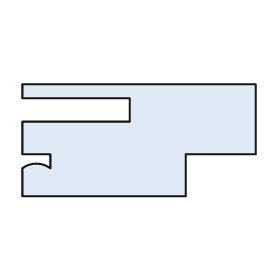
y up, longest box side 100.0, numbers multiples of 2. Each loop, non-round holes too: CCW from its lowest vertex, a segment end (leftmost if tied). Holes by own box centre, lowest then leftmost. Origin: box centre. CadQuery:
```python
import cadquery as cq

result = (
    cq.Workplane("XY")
    .moveTo(-50.0, -24.0)
    .lineTo(20.0, -24.0)
    .lineTo(20.0, -6.0)
    .lineTo(50.0, -6.0)
    .lineTo(50.0, 24.0)
    .lineTo(-50.0, 24.0)
    .lineTo(-50.0, 18.0)
    .lineTo(-4.0, 18.0)
    .lineTo(-4.0, 8.0)
    .lineTo(-50.0, 8.0)
    .lineTo(-50.0, -6.0)
    .lineTo(-38.0, -6.0)
    .lineTo(-38.0, -12.0)
    .threePointArc((-44.0, -10.0), (-50.0, -12.0))
    .close()
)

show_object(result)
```